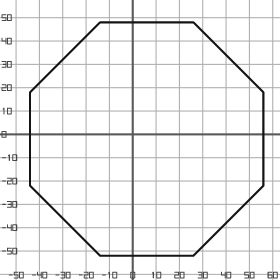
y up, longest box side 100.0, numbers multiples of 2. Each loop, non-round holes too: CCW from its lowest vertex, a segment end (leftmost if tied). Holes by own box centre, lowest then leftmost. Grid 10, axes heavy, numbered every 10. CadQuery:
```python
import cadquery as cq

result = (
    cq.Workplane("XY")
    .moveTo(-14.0, -52.0)
    .lineTo(26.0, -52.0)
    .lineTo(56.0, -22.0)
    .lineTo(56.0, 18.0)
    .lineTo(26.0, 48.0)
    .lineTo(-14.0, 48.0)
    .lineTo(-44.0, 18.0)
    .lineTo(-44.0, -22.0)
    .close()
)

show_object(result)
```